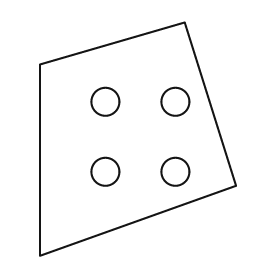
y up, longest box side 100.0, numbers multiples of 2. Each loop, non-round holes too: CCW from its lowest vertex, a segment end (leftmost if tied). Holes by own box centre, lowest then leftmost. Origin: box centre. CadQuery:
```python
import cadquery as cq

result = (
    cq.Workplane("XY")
    .moveTo(-42.0, -50.0)
    .lineTo(42.0, -20.0)
    .lineTo(20.0, 50.0)
    .lineTo(-42.0, 32.0)
    .close()
    .moveTo(-14.0, -14.0)
    .circle(6.0)
    .moveTo(16.0, -14.0)
    .circle(6.0)
    .moveTo(-14.0, 16.0)
    .circle(6.0)
    .moveTo(16.0, 16.0)
    .circle(6.0)
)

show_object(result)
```